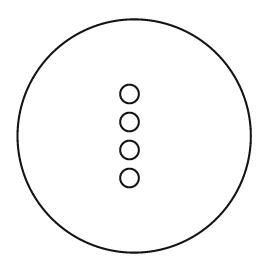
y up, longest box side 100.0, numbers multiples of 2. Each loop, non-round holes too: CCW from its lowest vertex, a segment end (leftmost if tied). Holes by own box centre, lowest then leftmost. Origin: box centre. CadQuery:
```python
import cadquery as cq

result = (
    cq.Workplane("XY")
    .moveTo(0.0, 0.0)
    .circle(50.0)
    .moveTo(-2.0, -18.0)
    .circle(4.0)
    .moveTo(-2.0, -6.0)
    .circle(4.0)
    .moveTo(-2.0, 6.0)
    .circle(4.0)
    .moveTo(-2.0, 18.0)
    .circle(4.0)
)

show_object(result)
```